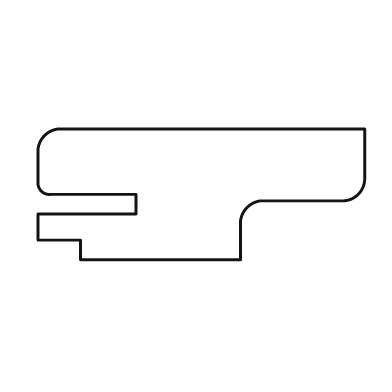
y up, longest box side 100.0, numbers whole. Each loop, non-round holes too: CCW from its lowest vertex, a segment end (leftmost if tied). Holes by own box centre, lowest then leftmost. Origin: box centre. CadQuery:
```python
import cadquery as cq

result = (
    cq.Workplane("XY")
    .moveTo(-37.0, -20.0)
    .lineTo(12.0, -20.0)
    .lineTo(12.0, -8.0)
    .threePointArc((14.0, -4.0), (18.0, -2.0))
    .lineTo(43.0, -2.0)
    .threePointArc((48.0, 0.0), (50.0, 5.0))
    .lineTo(50.0, 20.0)
    .lineTo(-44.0, 20.0)
    .threePointArc((-48.0, 18.0), (-50.0, 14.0))
    .lineTo(-50.0, 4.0)
    .threePointArc((-49.0, 1.0), (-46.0, 0.0))
    .lineTo(-20.0, 0.0)
    .lineTo(-20.0, -6.0)
    .lineTo(-50.0, -6.0)
    .lineTo(-50.0, -14.0)
    .lineTo(-37.0, -14.0)
    .close()
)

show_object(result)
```